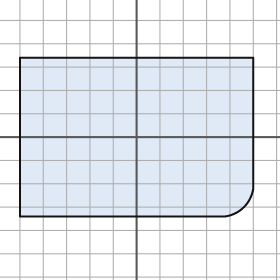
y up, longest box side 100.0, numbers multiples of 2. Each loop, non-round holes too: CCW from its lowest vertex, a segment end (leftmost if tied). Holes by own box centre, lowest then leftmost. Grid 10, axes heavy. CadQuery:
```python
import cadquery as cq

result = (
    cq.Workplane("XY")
    .moveTo(-50.0, -34.0)
    .lineTo(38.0, -34.0)
    .threePointArc((46.0, -30.0), (50.0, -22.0))
    .lineTo(50.0, 34.0)
    .lineTo(-50.0, 34.0)
    .close()
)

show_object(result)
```